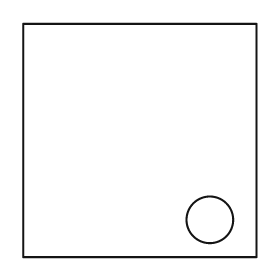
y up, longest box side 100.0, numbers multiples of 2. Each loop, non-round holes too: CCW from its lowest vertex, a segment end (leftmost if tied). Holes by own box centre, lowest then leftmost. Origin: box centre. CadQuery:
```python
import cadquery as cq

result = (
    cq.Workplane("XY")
    .moveTo(-50.0, -50.0)
    .lineTo(50.0, -50.0)
    .lineTo(50.0, 50.0)
    .lineTo(-50.0, 50.0)
    .close()
    .moveTo(30.0, -34.0)
    .circle(10.0)
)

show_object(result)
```